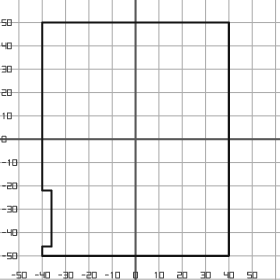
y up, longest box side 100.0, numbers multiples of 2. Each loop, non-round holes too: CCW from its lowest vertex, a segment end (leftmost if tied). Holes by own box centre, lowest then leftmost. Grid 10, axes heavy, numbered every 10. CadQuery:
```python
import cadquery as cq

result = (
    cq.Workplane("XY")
    .moveTo(-40.0, -50.0)
    .lineTo(40.0, -50.0)
    .lineTo(40.0, 50.0)
    .lineTo(-40.0, 50.0)
    .lineTo(-40.0, -22.0)
    .lineTo(-36.0, -22.0)
    .lineTo(-36.0, -46.0)
    .lineTo(-40.0, -46.0)
    .close()
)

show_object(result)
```